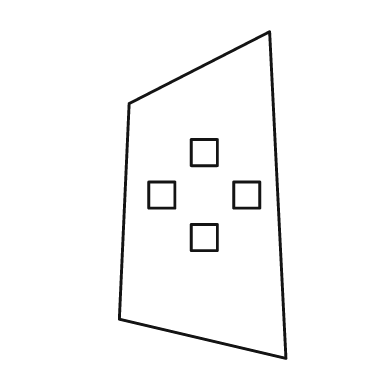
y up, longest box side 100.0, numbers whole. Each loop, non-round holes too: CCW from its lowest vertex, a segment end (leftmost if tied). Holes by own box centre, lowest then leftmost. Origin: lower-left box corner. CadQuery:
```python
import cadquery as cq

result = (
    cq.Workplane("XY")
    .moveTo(51.0, 0.0)
    .lineTo(46.0, 100.0)
    .lineTo(3.0, 78.0)
    .lineTo(0.0, 12.0)
    .close()
    .moveTo(22.0, 33.0)
    .lineTo(30.0, 33.0)
    .lineTo(30.0, 41.0)
    .lineTo(22.0, 41.0)
    .close()
    .moveTo(9.0, 46.0)
    .lineTo(17.0, 46.0)
    .lineTo(17.0, 54.0)
    .lineTo(9.0, 54.0)
    .close()
    .moveTo(35.0, 46.0)
    .lineTo(43.0, 46.0)
    .lineTo(43.0, 54.0)
    .lineTo(35.0, 54.0)
    .close()
    .moveTo(22.0, 59.0)
    .lineTo(30.0, 59.0)
    .lineTo(30.0, 67.0)
    .lineTo(22.0, 67.0)
    .close()
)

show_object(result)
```